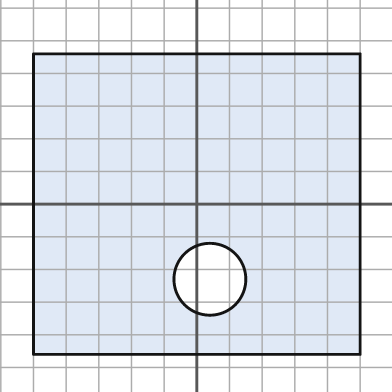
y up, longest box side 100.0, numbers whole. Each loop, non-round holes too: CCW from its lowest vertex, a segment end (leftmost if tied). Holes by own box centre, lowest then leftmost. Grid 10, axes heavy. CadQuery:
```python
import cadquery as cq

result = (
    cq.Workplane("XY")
    .moveTo(-50.0, -46.0)
    .lineTo(50.0, -46.0)
    .lineTo(50.0, 46.0)
    .lineTo(-50.0, 46.0)
    .close()
    .moveTo(4.0, -23.0)
    .circle(11.0)
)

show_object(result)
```